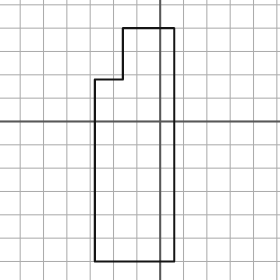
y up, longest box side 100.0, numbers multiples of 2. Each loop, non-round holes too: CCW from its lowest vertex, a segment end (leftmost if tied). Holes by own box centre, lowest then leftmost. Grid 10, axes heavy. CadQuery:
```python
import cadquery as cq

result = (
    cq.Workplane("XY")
    .moveTo(-28.0, -60.0)
    .lineTo(6.0, -60.0)
    .lineTo(6.0, 40.0)
    .lineTo(-16.0, 40.0)
    .lineTo(-16.0, 18.0)
    .lineTo(-28.0, 18.0)
    .close()
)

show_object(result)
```